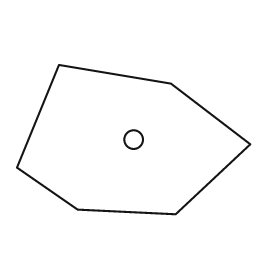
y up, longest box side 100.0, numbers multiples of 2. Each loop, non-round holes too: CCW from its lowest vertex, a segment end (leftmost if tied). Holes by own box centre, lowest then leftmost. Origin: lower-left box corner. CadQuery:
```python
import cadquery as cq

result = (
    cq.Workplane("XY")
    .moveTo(68.0, 0.0)
    .lineTo(100.0, 30.0)
    .lineTo(66.0, 56.0)
    .lineTo(18.0, 64.0)
    .lineTo(0.0, 20.0)
    .lineTo(26.0, 2.0)
    .close()
    .moveTo(50.0, 32.0)
    .circle(4.0)
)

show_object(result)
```